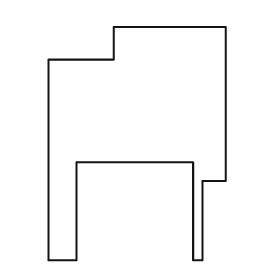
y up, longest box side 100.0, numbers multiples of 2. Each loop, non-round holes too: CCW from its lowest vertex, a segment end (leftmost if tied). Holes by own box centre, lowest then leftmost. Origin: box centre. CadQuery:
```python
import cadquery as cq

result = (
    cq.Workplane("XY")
    .moveTo(-38.0, -50.0)
    .lineTo(-26.0, -50.0)
    .lineTo(-26.0, -8.0)
    .lineTo(24.0, -8.0)
    .lineTo(24.0, -50.0)
    .lineTo(28.0, -50.0)
    .lineTo(28.0, -16.0)
    .lineTo(38.0, -16.0)
    .lineTo(38.0, 50.0)
    .lineTo(-10.0, 50.0)
    .lineTo(-10.0, 36.0)
    .lineTo(-38.0, 36.0)
    .close()
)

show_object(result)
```